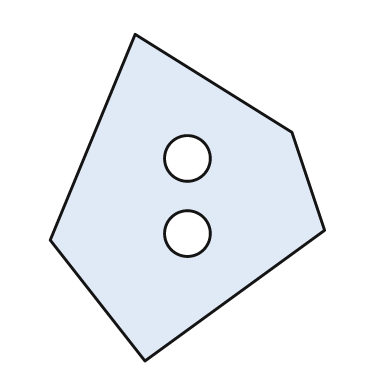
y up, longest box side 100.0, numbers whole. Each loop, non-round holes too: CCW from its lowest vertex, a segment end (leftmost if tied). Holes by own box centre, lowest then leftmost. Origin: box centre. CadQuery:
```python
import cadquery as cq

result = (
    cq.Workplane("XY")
    .moveTo(-13.0, -50.0)
    .lineTo(42.0, -10.0)
    .lineTo(32.0, 20.0)
    .lineTo(-16.0, 50.0)
    .lineTo(-42.0, -13.0)
    .close()
    .moveTo(0.0, -11.0)
    .circle(7.0)
    .moveTo(0.0, 12.0)
    .circle(7.0)
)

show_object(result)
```